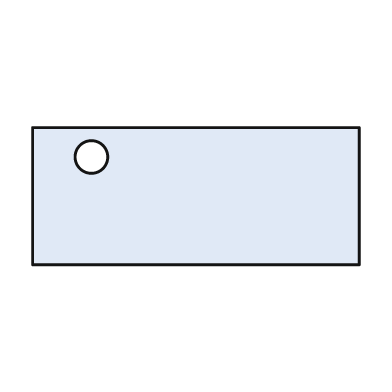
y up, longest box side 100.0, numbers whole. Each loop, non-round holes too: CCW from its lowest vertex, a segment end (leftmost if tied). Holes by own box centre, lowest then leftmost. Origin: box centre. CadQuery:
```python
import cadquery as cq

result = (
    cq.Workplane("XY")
    .moveTo(-50.0, -21.0)
    .lineTo(50.0, -21.0)
    .lineTo(50.0, 21.0)
    .lineTo(-50.0, 21.0)
    .close()
    .moveTo(-32.0, 12.0)
    .circle(5.0)
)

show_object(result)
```